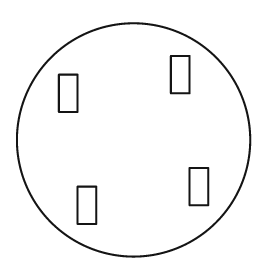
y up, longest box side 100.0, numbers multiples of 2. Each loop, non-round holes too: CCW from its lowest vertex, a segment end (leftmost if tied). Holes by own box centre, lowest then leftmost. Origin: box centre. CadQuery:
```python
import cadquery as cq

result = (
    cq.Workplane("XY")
    .moveTo(0.0, 0.0)
    .circle(50.0)
    .moveTo(-24.0, -36.0)
    .lineTo(-16.0, -36.0)
    .lineTo(-16.0, -20.0)
    .lineTo(-24.0, -20.0)
    .close()
    .moveTo(24.0, -28.0)
    .lineTo(32.0, -28.0)
    .lineTo(32.0, -12.0)
    .lineTo(24.0, -12.0)
    .close()
    .moveTo(-32.0, 12.0)
    .lineTo(-24.0, 12.0)
    .lineTo(-24.0, 28.0)
    .lineTo(-32.0, 28.0)
    .close()
    .moveTo(16.0, 20.0)
    .lineTo(24.0, 20.0)
    .lineTo(24.0, 36.0)
    .lineTo(16.0, 36.0)
    .close()
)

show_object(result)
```